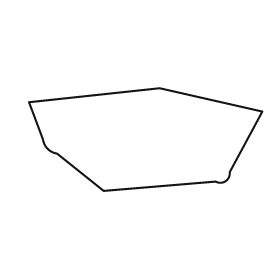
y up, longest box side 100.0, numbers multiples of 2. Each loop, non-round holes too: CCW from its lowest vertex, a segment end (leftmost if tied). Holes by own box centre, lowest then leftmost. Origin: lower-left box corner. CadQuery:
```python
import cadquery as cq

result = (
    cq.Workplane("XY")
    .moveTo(32.0, 0.0)
    .lineTo(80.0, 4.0)
    .threePointArc((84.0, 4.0), (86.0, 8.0))
    .lineTo(100.0, 34.0)
    .lineTo(56.0, 44.0)
    .lineTo(0.0, 38.0)
    .lineTo(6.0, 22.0)
    .threePointArc((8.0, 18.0), (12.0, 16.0))
    .close()
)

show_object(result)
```